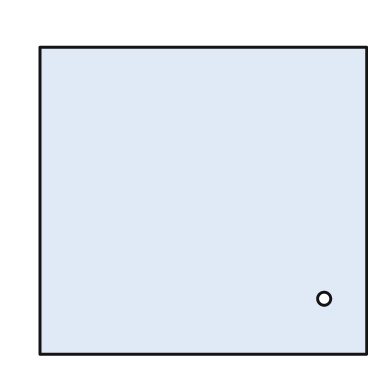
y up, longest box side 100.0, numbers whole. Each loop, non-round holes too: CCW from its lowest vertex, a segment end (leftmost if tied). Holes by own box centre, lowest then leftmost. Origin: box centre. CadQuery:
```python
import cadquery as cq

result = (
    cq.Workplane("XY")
    .moveTo(-50.0, -47.0)
    .lineTo(50.0, -47.0)
    .lineTo(50.0, 47.0)
    .lineTo(-50.0, 47.0)
    .close()
    .moveTo(37.0, -30.0)
    .circle(2.0)
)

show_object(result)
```